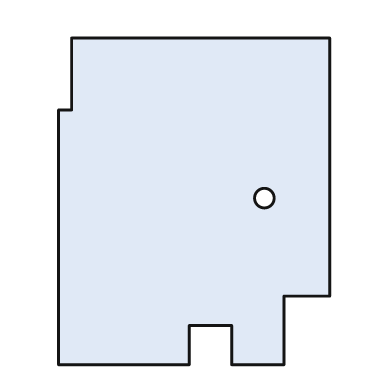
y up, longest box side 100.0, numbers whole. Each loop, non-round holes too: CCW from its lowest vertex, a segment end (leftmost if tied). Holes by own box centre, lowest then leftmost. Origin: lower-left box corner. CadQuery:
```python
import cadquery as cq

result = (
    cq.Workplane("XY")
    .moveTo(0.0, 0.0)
    .lineTo(40.0, 0.0)
    .lineTo(40.0, 12.0)
    .lineTo(53.0, 12.0)
    .lineTo(53.0, 0.0)
    .lineTo(69.0, 0.0)
    .lineTo(69.0, 21.0)
    .lineTo(83.0, 21.0)
    .lineTo(83.0, 100.0)
    .lineTo(4.0, 100.0)
    .lineTo(4.0, 78.0)
    .lineTo(0.0, 78.0)
    .close()
    .moveTo(63.0, 51.0)
    .circle(3.0)
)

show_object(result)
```